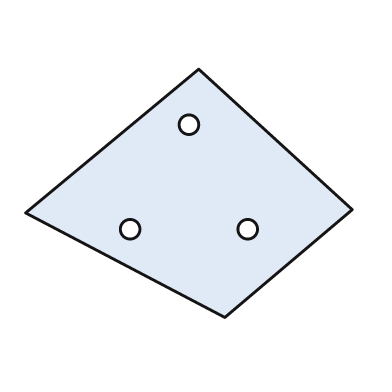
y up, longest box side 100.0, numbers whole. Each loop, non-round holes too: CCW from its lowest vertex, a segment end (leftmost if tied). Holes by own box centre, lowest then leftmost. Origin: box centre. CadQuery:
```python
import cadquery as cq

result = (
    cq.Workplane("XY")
    .moveTo(11.0, -38.0)
    .lineTo(50.0, -5.0)
    .lineTo(3.0, 38.0)
    .lineTo(-50.0, -6.0)
    .close()
    .moveTo(-18.0, -11.0)
    .circle(3.0)
    .moveTo(18.0, -11.0)
    .circle(3.0)
    .moveTo(0.0, 21.0)
    .circle(3.0)
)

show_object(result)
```